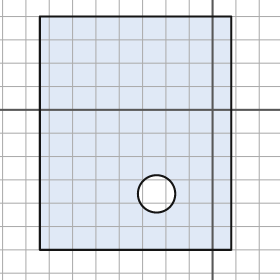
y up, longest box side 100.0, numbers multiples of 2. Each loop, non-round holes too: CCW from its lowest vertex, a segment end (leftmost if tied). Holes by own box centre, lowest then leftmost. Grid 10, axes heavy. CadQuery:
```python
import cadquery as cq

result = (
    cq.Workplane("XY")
    .moveTo(-74.0, -60.0)
    .lineTo(8.0, -60.0)
    .lineTo(8.0, 40.0)
    .lineTo(-74.0, 40.0)
    .close()
    .moveTo(-24.0, -36.0)
    .circle(8.0)
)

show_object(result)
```